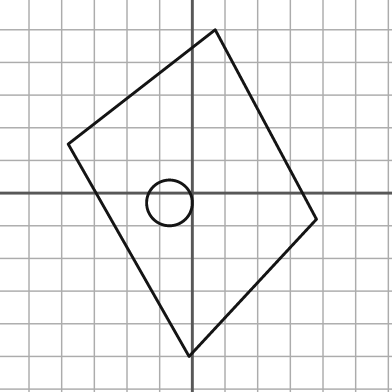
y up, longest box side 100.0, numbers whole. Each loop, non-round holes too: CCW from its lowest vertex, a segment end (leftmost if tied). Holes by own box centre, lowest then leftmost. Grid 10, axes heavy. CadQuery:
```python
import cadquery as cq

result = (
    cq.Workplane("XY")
    .moveTo(-1.0, -50.0)
    .lineTo(38.0, -8.0)
    .lineTo(7.0, 50.0)
    .lineTo(-38.0, 15.0)
    .close()
    .moveTo(-7.0, -3.0)
    .circle(7.0)
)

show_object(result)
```